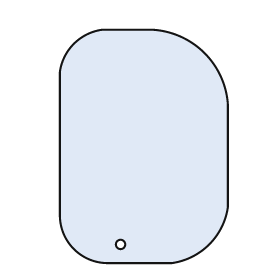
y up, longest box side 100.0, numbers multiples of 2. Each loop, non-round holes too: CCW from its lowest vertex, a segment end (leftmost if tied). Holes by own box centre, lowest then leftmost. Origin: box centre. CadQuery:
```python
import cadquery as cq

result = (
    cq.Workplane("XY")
    .moveTo(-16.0, -50.0)
    .lineTo(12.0, -50.0)
    .threePointArc((28.0, -42.0), (36.0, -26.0))
    .lineTo(36.0, 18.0)
    .threePointArc((26.0, 40.0), (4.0, 50.0))
    .lineTo(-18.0, 50.0)
    .threePointArc((-30.0, 44.0), (-36.0, 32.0))
    .lineTo(-36.0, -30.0)
    .threePointArc((-30.0, -44.0), (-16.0, -50.0))
    .close()
    .moveTo(-10.0, -42.0)
    .circle(2.0)
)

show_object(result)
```